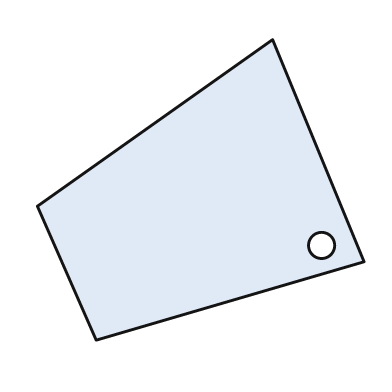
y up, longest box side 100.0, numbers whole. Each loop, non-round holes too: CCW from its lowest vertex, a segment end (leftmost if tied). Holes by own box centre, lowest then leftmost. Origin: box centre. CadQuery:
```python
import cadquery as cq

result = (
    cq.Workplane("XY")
    .moveTo(-32.0, -46.0)
    .lineTo(50.0, -22.0)
    .lineTo(22.0, 46.0)
    .lineTo(-50.0, -5.0)
    .close()
    .moveTo(37.0, -17.0)
    .circle(4.0)
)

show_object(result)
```